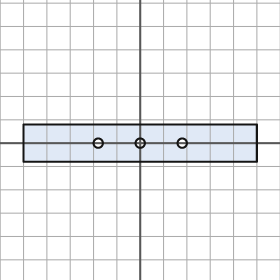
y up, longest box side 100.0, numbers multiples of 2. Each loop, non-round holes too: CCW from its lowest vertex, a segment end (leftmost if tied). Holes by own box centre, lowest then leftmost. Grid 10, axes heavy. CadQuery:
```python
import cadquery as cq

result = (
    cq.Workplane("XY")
    .moveTo(-50.0, -8.0)
    .lineTo(50.0, -8.0)
    .lineTo(50.0, 8.0)
    .lineTo(-50.0, 8.0)
    .close()
    .moveTo(-18.0, 0.0)
    .circle(2.0)
    .moveTo(0.0, 0.0)
    .circle(2.0)
    .moveTo(18.0, 0.0)
    .circle(2.0)
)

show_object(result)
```